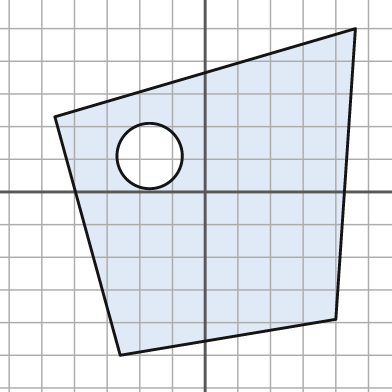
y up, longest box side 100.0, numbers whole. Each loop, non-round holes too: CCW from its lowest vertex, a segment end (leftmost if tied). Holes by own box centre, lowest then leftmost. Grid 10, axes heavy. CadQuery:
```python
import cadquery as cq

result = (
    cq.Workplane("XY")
    .moveTo(-26.0, -50.0)
    .lineTo(40.0, -39.0)
    .lineTo(46.0, 50.0)
    .lineTo(-46.0, 23.0)
    .close()
    .moveTo(-17.0, 11.0)
    .circle(10.0)
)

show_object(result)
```